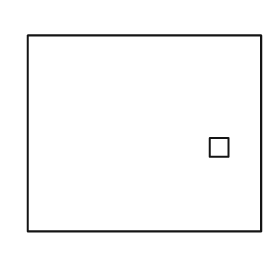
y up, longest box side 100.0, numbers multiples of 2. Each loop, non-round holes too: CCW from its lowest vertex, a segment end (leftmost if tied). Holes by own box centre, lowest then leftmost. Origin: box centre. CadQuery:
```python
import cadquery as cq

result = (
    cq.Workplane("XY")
    .moveTo(-50.0, -42.0)
    .lineTo(50.0, -42.0)
    .lineTo(50.0, 42.0)
    .lineTo(-50.0, 42.0)
    .close()
    .moveTo(28.0, -10.0)
    .lineTo(36.0, -10.0)
    .lineTo(36.0, -2.0)
    .lineTo(28.0, -2.0)
    .close()
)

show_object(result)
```